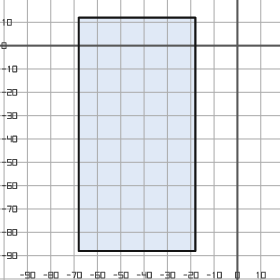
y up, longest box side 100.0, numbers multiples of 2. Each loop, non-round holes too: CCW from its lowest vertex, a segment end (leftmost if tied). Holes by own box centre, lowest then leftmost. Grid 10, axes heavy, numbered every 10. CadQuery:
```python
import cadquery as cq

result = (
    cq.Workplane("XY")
    .moveTo(-68.0, -88.0)
    .lineTo(-18.0, -88.0)
    .lineTo(-18.0, 12.0)
    .lineTo(-68.0, 12.0)
    .close()
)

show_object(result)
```